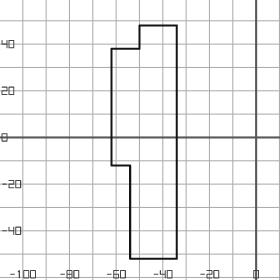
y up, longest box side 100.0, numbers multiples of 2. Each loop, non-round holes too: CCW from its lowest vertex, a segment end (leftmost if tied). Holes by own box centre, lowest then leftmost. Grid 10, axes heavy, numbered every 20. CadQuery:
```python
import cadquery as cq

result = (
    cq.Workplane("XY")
    .moveTo(-54.0, -52.0)
    .lineTo(-34.0, -52.0)
    .lineTo(-34.0, 48.0)
    .lineTo(-50.0, 48.0)
    .lineTo(-50.0, 38.0)
    .lineTo(-62.0, 38.0)
    .lineTo(-62.0, -12.0)
    .lineTo(-54.0, -12.0)
    .close()
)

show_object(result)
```